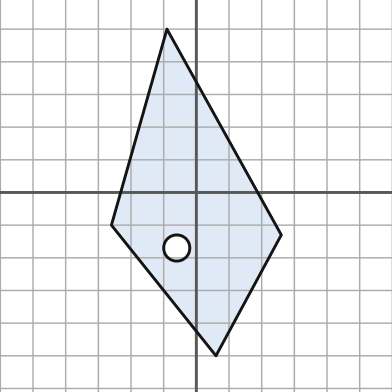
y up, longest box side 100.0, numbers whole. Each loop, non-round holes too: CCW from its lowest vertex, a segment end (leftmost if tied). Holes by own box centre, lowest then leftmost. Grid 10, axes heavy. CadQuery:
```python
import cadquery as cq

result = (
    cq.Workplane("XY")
    .moveTo(6.0, -50.0)
    .lineTo(26.0, -13.0)
    .lineTo(-9.0, 50.0)
    .lineTo(-26.0, -10.0)
    .close()
    .moveTo(-6.0, -17.0)
    .circle(4.0)
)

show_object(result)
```